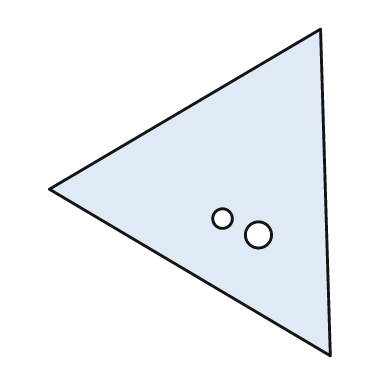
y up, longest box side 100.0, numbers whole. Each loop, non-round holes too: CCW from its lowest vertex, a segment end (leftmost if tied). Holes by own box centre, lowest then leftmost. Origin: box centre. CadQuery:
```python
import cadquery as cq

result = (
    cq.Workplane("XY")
    .moveTo(43.0, -50.0)
    .lineTo(40.0, 50.0)
    .lineTo(-43.0, 1.0)
    .close()
    .moveTo(21.0, -13.0)
    .circle(4.0)
    .moveTo(10.0, -8.0)
    .circle(3.0)
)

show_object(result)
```